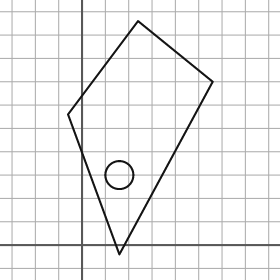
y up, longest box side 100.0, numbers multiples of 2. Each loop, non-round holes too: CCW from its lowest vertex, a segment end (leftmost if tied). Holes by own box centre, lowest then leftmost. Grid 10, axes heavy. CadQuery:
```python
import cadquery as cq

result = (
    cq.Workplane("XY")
    .moveTo(16.0, -4.0)
    .lineTo(56.0, 70.0)
    .lineTo(24.0, 96.0)
    .lineTo(-6.0, 56.0)
    .close()
    .moveTo(16.0, 30.0)
    .circle(6.0)
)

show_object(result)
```